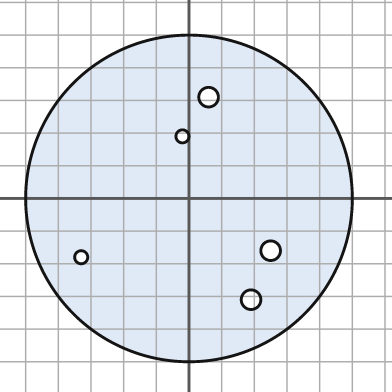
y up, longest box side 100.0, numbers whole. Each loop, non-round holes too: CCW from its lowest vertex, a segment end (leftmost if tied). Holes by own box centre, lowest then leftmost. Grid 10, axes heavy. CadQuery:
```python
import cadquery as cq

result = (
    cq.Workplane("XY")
    .moveTo(0.0, 0.0)
    .circle(50.0)
    .moveTo(19.0, -31.0)
    .circle(3.0)
    .moveTo(-33.0, -18.0)
    .circle(2.0)
    .moveTo(25.0, -16.0)
    .circle(3.0)
    .moveTo(-2.0, 19.0)
    .circle(2.0)
    .moveTo(6.0, 31.0)
    .circle(3.0)
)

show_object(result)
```